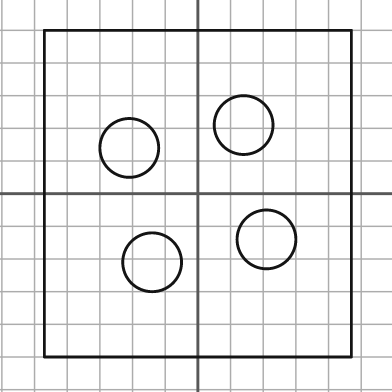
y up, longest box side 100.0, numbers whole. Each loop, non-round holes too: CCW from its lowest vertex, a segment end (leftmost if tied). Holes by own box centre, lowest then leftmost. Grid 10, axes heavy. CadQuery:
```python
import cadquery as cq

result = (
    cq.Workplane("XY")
    .moveTo(-47.0, -50.0)
    .lineTo(47.0, -50.0)
    .lineTo(47.0, 50.0)
    .lineTo(-47.0, 50.0)
    .close()
    .moveTo(-14.0, -21.0)
    .circle(9.0)
    .moveTo(21.0, -14.0)
    .circle(9.0)
    .moveTo(-21.0, 14.0)
    .circle(9.0)
    .moveTo(14.0, 21.0)
    .circle(9.0)
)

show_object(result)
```